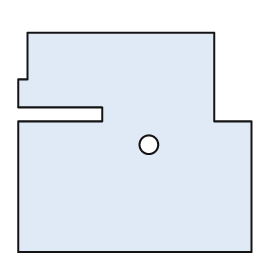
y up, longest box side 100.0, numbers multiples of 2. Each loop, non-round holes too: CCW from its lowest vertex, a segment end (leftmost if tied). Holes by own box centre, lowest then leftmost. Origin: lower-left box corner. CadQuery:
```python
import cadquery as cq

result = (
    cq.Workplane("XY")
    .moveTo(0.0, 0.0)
    .lineTo(100.0, 0.0)
    .lineTo(100.0, 56.0)
    .lineTo(84.0, 56.0)
    .lineTo(84.0, 94.0)
    .lineTo(4.0, 94.0)
    .lineTo(4.0, 74.0)
    .lineTo(0.0, 74.0)
    .lineTo(0.0, 62.0)
    .lineTo(36.0, 62.0)
    .lineTo(36.0, 56.0)
    .lineTo(0.0, 56.0)
    .close()
    .moveTo(56.0, 46.0)
    .circle(4.0)
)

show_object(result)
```